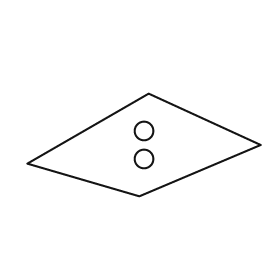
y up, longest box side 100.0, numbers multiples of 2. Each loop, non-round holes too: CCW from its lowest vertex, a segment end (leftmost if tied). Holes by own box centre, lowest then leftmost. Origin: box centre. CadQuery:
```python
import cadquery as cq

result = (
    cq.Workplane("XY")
    .moveTo(-2.0, -22.0)
    .lineTo(50.0, 0.0)
    .lineTo(2.0, 22.0)
    .lineTo(-50.0, -8.0)
    .close()
    .moveTo(0.0, -6.0)
    .circle(4.0)
    .moveTo(0.0, 6.0)
    .circle(4.0)
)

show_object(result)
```